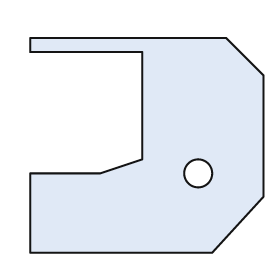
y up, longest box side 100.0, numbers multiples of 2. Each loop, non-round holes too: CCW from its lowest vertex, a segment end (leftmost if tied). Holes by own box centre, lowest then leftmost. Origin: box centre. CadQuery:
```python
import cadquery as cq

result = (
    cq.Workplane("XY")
    .moveTo(-50.0, -46.0)
    .lineTo(28.0, -46.0)
    .lineTo(50.0, -22.0)
    .lineTo(50.0, 30.0)
    .lineTo(34.0, 46.0)
    .lineTo(-50.0, 46.0)
    .lineTo(-50.0, 40.0)
    .lineTo(-2.0, 40.0)
    .lineTo(-2.0, -6.0)
    .lineTo(-20.0, -12.0)
    .lineTo(-50.0, -12.0)
    .close()
    .moveTo(22.0, -12.0)
    .circle(6.0)
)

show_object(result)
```